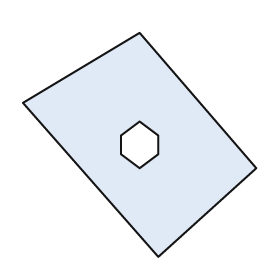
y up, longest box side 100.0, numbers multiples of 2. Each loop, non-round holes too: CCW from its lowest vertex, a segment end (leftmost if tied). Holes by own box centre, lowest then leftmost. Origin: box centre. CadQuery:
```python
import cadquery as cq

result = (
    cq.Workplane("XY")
    .moveTo(8.0, -48.0)
    .lineTo(50.0, -10.0)
    .lineTo(0.0, 48.0)
    .lineTo(-50.0, 18.0)
    .close()
    .moveTo(0.0, -10.0)
    .lineTo(8.0, -4.0)
    .lineTo(8.0, 4.0)
    .lineTo(0.0, 10.0)
    .lineTo(-8.0, 4.0)
    .lineTo(-8.0, -4.0)
    .close()
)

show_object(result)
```